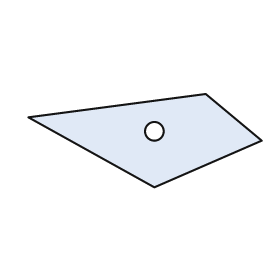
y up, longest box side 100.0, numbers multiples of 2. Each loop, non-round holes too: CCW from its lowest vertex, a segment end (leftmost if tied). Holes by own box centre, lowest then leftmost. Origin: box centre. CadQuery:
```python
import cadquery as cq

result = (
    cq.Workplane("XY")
    .moveTo(4.0, -20.0)
    .lineTo(50.0, 0.0)
    .lineTo(26.0, 20.0)
    .lineTo(-50.0, 10.0)
    .close()
    .moveTo(4.0, 4.0)
    .circle(4.0)
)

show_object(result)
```